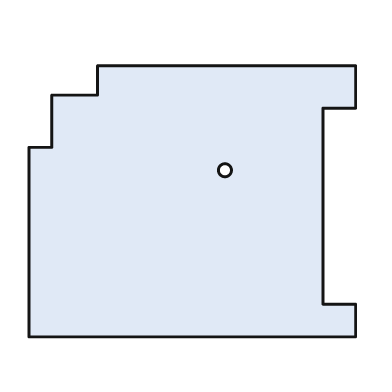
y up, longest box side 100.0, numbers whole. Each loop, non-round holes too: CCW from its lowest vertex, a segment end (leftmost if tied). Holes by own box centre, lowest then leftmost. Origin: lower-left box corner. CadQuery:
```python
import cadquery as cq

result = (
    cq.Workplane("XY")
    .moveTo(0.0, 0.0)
    .lineTo(100.0, 0.0)
    .lineTo(100.0, 10.0)
    .lineTo(90.0, 10.0)
    .lineTo(90.0, 70.0)
    .lineTo(100.0, 70.0)
    .lineTo(100.0, 83.0)
    .lineTo(21.0, 83.0)
    .lineTo(21.0, 74.0)
    .lineTo(7.0, 74.0)
    .lineTo(7.0, 58.0)
    .lineTo(0.0, 58.0)
    .close()
    .moveTo(60.0, 51.0)
    .circle(2.0)
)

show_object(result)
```